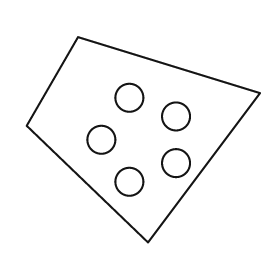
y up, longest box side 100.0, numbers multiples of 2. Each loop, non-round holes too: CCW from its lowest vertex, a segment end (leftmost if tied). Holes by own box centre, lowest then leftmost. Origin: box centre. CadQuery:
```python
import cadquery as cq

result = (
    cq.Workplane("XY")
    .moveTo(2.0, -44.0)
    .lineTo(50.0, 20.0)
    .lineTo(-28.0, 44.0)
    .lineTo(-50.0, 6.0)
    .close()
    .moveTo(-6.0, -18.0)
    .circle(6.0)
    .moveTo(14.0, -10.0)
    .circle(6.0)
    .moveTo(-18.0, 0.0)
    .circle(6.0)
    .moveTo(14.0, 10.0)
    .circle(6.0)
    .moveTo(-6.0, 18.0)
    .circle(6.0)
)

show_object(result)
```